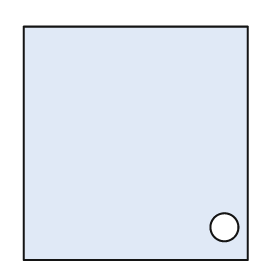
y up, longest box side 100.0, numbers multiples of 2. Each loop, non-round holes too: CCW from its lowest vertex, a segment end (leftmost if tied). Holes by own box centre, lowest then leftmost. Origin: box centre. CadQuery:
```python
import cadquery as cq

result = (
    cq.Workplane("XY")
    .moveTo(-48.0, -50.0)
    .lineTo(48.0, -50.0)
    .lineTo(48.0, 50.0)
    .lineTo(-48.0, 50.0)
    .close()
    .moveTo(38.0, -36.0)
    .circle(6.0)
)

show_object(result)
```